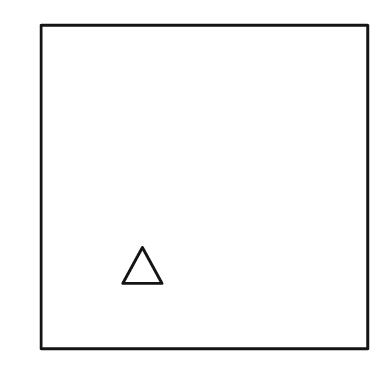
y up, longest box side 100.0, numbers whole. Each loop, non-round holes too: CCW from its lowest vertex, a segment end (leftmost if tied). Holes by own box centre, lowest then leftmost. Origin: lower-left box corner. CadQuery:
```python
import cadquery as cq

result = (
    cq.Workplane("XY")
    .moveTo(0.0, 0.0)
    .lineTo(100.0, 0.0)
    .lineTo(100.0, 99.0)
    .lineTo(0.0, 99.0)
    .close()
    .moveTo(25.0, 20.0)
    .lineTo(37.0, 20.0)
    .lineTo(31.0, 31.0)
    .close()
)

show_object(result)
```